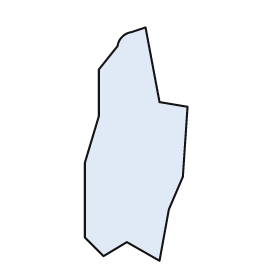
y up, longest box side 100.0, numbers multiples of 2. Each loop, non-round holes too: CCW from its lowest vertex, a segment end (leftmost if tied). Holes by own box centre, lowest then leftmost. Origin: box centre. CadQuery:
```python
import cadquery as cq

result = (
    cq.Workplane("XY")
    .moveTo(10.0, -50.0)
    .lineTo(14.0, -28.0)
    .lineTo(20.0, -14.0)
    .lineTo(22.0, 16.0)
    .lineTo(10.0, 18.0)
    .lineTo(4.0, 50.0)
    .lineTo(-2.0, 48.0)
    .threePointArc((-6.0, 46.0), (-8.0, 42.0))
    .lineTo(-16.0, 32.0)
    .lineTo(-16.0, 12.0)
    .lineTo(-22.0, -8.0)
    .lineTo(-22.0, -40.0)
    .lineTo(-14.0, -48.0)
    .lineTo(-4.0, -42.0)
    .close()
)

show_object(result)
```